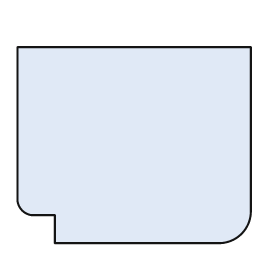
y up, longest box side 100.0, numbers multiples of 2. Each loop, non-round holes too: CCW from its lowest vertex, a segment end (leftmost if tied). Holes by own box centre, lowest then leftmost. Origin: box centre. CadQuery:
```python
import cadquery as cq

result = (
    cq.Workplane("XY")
    .moveTo(-34.0, -42.0)
    .lineTo(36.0, -42.0)
    .threePointArc((46.0, -38.0), (50.0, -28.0))
    .lineTo(50.0, 42.0)
    .lineTo(-50.0, 42.0)
    .lineTo(-50.0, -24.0)
    .threePointArc((-48.0, -28.0), (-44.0, -30.0))
    .lineTo(-34.0, -30.0)
    .close()
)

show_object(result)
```